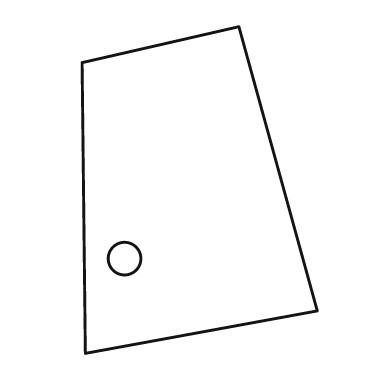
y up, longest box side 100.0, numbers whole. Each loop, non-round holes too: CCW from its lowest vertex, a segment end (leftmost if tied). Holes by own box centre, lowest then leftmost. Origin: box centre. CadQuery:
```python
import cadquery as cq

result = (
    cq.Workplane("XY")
    .moveTo(-35.0, -50.0)
    .lineTo(36.0, -37.0)
    .lineTo(12.0, 50.0)
    .lineTo(-36.0, 39.0)
    .close()
    .moveTo(-23.0, -21.0)
    .circle(5.0)
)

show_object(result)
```